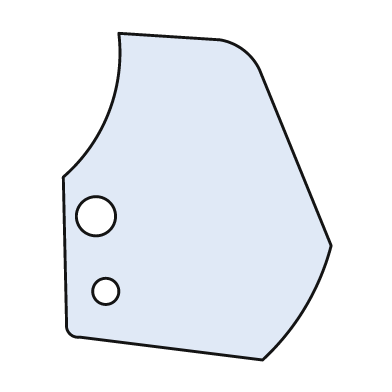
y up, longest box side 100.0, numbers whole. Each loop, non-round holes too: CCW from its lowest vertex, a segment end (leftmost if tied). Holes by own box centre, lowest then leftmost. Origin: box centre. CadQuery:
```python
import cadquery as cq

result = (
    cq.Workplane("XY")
    .moveTo(20.0, -50.0)
    .threePointArc((33.0, -34.0), (41.0, -15.0))
    .lineTo(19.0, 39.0)
    .threePointArc((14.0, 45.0), (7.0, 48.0))
    .lineTo(-24.0, 50.0)
    .threePointArc((-27.0, 26.0), (-41.0, 6.0))
    .lineTo(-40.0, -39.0)
    .threePointArc((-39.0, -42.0), (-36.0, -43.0))
    .close()
    .moveTo(-28.0, -29.0)
    .circle(4.0)
    .moveTo(-31.0, -6.0)
    .circle(6.0)
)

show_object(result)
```